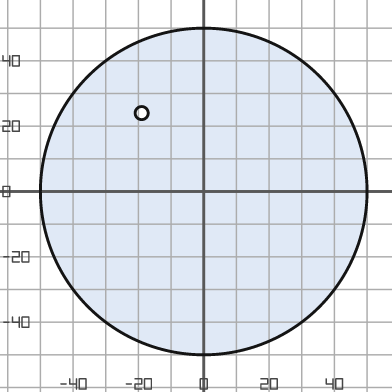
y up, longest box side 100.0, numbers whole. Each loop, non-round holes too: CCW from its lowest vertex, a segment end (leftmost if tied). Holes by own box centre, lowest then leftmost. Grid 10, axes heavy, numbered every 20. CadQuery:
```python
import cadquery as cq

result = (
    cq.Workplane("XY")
    .moveTo(0.0, 0.0)
    .circle(50.0)
    .moveTo(-19.0, 24.0)
    .circle(2.0)
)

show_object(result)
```